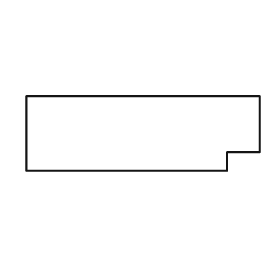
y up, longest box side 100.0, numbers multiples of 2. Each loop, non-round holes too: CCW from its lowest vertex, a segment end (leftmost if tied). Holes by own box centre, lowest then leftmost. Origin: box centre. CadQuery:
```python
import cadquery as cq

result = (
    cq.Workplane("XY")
    .moveTo(-50.0, -16.0)
    .lineTo(36.0, -16.0)
    .lineTo(36.0, -8.0)
    .lineTo(50.0, -8.0)
    .lineTo(50.0, 16.0)
    .lineTo(-50.0, 16.0)
    .close()
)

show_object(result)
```